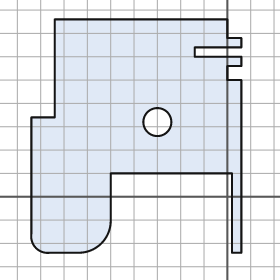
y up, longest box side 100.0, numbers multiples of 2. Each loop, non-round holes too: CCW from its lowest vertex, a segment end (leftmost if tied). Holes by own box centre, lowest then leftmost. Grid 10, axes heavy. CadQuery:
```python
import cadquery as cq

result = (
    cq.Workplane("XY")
    .moveTo(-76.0, -24.0)
    .lineTo(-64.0, -24.0)
    .threePointArc((-54.0, -20.0), (-50.0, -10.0))
    .lineTo(-50.0, 10.0)
    .lineTo(2.0, 10.0)
    .lineTo(2.0, -24.0)
    .lineTo(6.0, -24.0)
    .lineTo(6.0, 50.0)
    .lineTo(0.0, 50.0)
    .lineTo(0.0, 56.0)
    .lineTo(6.0, 56.0)
    .lineTo(6.0, 60.0)
    .lineTo(-14.0, 60.0)
    .lineTo(-14.0, 64.0)
    .lineTo(6.0, 64.0)
    .lineTo(6.0, 68.0)
    .lineTo(0.0, 68.0)
    .lineTo(0.0, 76.0)
    .lineTo(-74.0, 76.0)
    .lineTo(-74.0, 34.0)
    .lineTo(-84.0, 34.0)
    .lineTo(-84.0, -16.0)
    .threePointArc((-82.0, -22.0), (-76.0, -24.0))
    .close()
    .moveTo(-30.0, 32.0)
    .circle(6.0)
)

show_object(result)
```